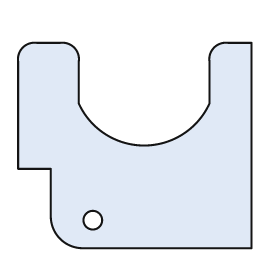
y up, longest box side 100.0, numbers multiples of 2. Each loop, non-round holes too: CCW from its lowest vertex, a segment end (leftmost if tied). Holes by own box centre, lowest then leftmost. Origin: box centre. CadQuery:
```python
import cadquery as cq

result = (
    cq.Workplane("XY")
    .moveTo(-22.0, -44.0)
    .lineTo(50.0, -44.0)
    .lineTo(50.0, 44.0)
    .lineTo(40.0, 44.0)
    .threePointArc((34.0, 42.0), (32.0, 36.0))
    .lineTo(32.0, 18.0)
    .threePointArc((4.0, 0.0), (-24.0, 18.0))
    .lineTo(-24.0, 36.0)
    .threePointArc((-26.0, 42.0), (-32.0, 44.0))
    .lineTo(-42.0, 44.0)
    .threePointArc((-48.0, 42.0), (-50.0, 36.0))
    .lineTo(-50.0, -10.0)
    .lineTo(-36.0, -10.0)
    .lineTo(-36.0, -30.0)
    .threePointArc((-32.0, -40.0), (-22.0, -44.0))
    .close()
    .moveTo(-18.0, -32.0)
    .circle(4.0)
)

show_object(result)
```